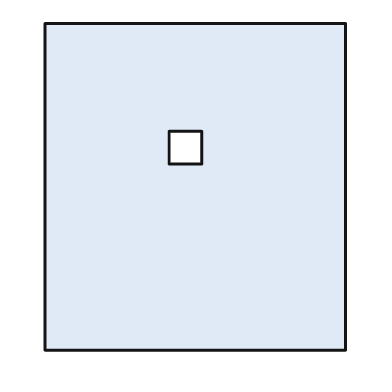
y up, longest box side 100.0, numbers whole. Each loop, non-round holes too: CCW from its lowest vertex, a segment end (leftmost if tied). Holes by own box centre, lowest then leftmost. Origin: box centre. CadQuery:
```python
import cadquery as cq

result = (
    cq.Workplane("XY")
    .moveTo(-46.0, -50.0)
    .lineTo(46.0, -50.0)
    .lineTo(46.0, 50.0)
    .lineTo(-46.0, 50.0)
    .close()
    .moveTo(-8.0, 7.0)
    .lineTo(2.0, 7.0)
    .lineTo(2.0, 17.0)
    .lineTo(-8.0, 17.0)
    .close()
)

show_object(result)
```